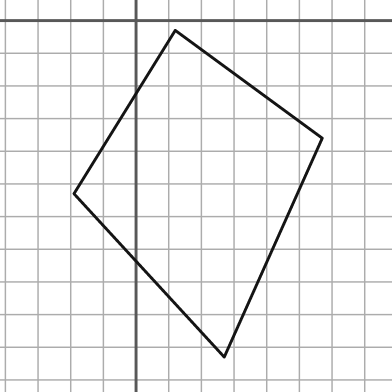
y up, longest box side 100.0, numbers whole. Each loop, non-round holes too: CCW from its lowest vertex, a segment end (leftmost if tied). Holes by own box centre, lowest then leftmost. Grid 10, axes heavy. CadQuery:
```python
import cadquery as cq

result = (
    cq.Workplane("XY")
    .moveTo(27.0, -103.0)
    .lineTo(57.0, -36.0)
    .lineTo(12.0, -3.0)
    .lineTo(-19.0, -53.0)
    .close()
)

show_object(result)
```